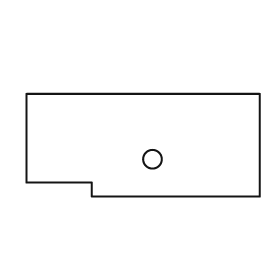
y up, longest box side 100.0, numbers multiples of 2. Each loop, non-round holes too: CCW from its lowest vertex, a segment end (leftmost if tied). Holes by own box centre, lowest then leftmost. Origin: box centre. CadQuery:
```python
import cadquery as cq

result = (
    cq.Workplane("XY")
    .moveTo(-22.0, -22.0)
    .lineTo(50.0, -22.0)
    .lineTo(50.0, 22.0)
    .lineTo(-50.0, 22.0)
    .lineTo(-50.0, -16.0)
    .lineTo(-22.0, -16.0)
    .close()
    .moveTo(4.0, -6.0)
    .circle(4.0)
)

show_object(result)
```